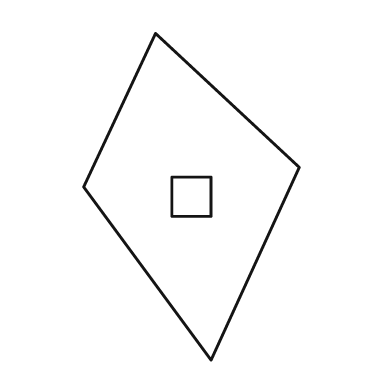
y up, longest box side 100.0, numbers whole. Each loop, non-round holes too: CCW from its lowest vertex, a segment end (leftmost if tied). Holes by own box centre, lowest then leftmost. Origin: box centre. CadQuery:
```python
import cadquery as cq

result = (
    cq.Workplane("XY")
    .moveTo(6.0, -50.0)
    .lineTo(33.0, 9.0)
    .lineTo(-11.0, 50.0)
    .lineTo(-33.0, 3.0)
    .close()
    .moveTo(-6.0, -6.0)
    .lineTo(6.0, -6.0)
    .lineTo(6.0, 6.0)
    .lineTo(-6.0, 6.0)
    .close()
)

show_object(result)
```